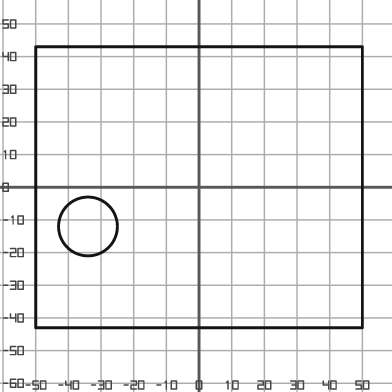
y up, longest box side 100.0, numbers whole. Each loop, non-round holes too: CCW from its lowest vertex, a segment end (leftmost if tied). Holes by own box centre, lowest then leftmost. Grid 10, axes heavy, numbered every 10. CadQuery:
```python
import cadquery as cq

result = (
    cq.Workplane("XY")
    .moveTo(-50.0, -43.0)
    .lineTo(50.0, -43.0)
    .lineTo(50.0, 43.0)
    .lineTo(-50.0, 43.0)
    .close()
    .moveTo(-34.0, -12.0)
    .circle(9.0)
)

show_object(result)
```